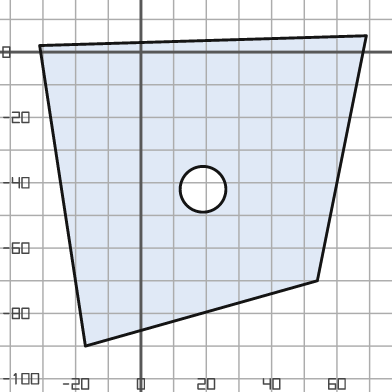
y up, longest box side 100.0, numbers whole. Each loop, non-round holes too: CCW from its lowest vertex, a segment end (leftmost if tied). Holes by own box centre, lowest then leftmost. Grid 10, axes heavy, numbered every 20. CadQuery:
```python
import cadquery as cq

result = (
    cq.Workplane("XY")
    .moveTo(-17.0, -90.0)
    .lineTo(54.0, -70.0)
    .lineTo(69.0, 5.0)
    .lineTo(-31.0, 2.0)
    .close()
    .moveTo(19.0, -42.0)
    .circle(7.0)
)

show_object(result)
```